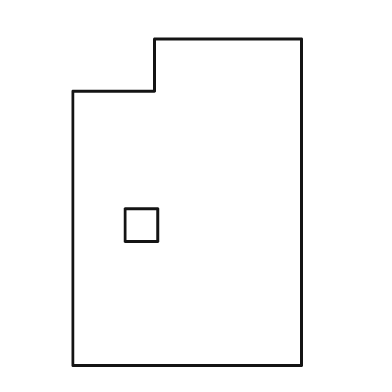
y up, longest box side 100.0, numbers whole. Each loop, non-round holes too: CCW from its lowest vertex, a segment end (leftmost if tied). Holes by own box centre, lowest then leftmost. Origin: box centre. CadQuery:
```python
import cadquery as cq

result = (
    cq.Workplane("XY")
    .moveTo(-35.0, -50.0)
    .lineTo(35.0, -50.0)
    .lineTo(35.0, 50.0)
    .lineTo(-10.0, 50.0)
    .lineTo(-10.0, 34.0)
    .lineTo(-35.0, 34.0)
    .close()
    .moveTo(-19.0, -12.0)
    .lineTo(-9.0, -12.0)
    .lineTo(-9.0, -2.0)
    .lineTo(-19.0, -2.0)
    .close()
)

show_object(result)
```